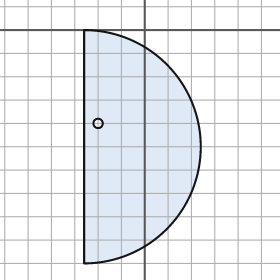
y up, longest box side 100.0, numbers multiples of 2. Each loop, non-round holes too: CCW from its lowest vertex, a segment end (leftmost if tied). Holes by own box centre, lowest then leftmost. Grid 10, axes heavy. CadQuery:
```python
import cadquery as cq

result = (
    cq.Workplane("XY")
    .moveTo(-26.0, -100.0)
    .threePointArc((24.0, -50.0), (-26.0, 0.0))
    .close()
    .moveTo(-20.0, -40.0)
    .circle(2.0)
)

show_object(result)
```